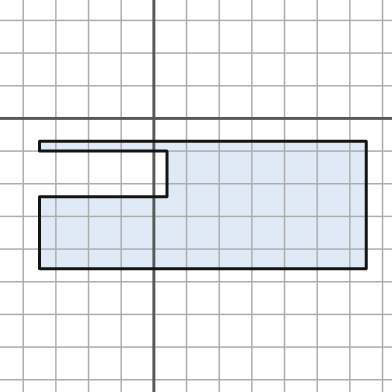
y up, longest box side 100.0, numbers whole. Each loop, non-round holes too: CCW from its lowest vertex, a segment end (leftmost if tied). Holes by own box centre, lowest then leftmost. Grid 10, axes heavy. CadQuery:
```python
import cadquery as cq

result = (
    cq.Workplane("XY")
    .moveTo(-35.0, -46.0)
    .lineTo(65.0, -46.0)
    .lineTo(65.0, -7.0)
    .lineTo(-35.0, -7.0)
    .lineTo(-35.0, -10.0)
    .lineTo(4.0, -10.0)
    .lineTo(4.0, -24.0)
    .lineTo(-35.0, -24.0)
    .close()
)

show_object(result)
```